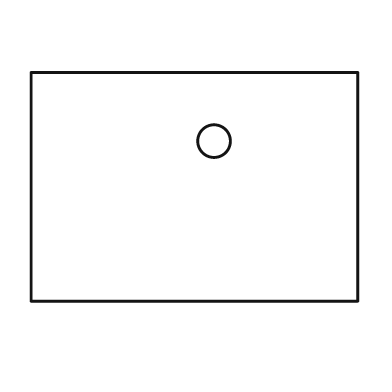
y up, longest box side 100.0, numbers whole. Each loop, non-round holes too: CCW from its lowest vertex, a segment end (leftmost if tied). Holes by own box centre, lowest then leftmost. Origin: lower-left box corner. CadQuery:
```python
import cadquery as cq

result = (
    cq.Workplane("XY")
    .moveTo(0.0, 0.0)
    .lineTo(100.0, 0.0)
    .lineTo(100.0, 70.0)
    .lineTo(0.0, 70.0)
    .close()
    .moveTo(56.0, 49.0)
    .circle(5.0)
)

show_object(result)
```